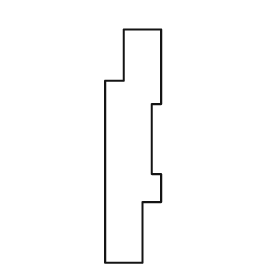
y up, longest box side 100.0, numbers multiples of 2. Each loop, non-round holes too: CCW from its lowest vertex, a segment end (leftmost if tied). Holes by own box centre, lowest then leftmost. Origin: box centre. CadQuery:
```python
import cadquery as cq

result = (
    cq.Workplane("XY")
    .moveTo(-12.0, -50.0)
    .lineTo(4.0, -50.0)
    .lineTo(4.0, -24.0)
    .lineTo(12.0, -24.0)
    .lineTo(12.0, -12.0)
    .lineTo(8.0, -12.0)
    .lineTo(8.0, 18.0)
    .lineTo(12.0, 18.0)
    .lineTo(12.0, 50.0)
    .lineTo(-4.0, 50.0)
    .lineTo(-4.0, 28.0)
    .lineTo(-12.0, 28.0)
    .close()
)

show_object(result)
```